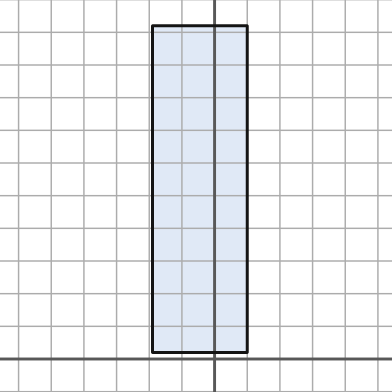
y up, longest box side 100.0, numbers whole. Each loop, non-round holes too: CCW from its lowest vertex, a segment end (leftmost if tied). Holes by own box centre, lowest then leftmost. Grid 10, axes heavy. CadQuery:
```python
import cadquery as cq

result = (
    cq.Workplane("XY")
    .moveTo(-19.0, 2.0)
    .lineTo(10.0, 2.0)
    .lineTo(10.0, 102.0)
    .lineTo(-19.0, 102.0)
    .close()
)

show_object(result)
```